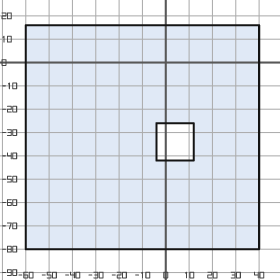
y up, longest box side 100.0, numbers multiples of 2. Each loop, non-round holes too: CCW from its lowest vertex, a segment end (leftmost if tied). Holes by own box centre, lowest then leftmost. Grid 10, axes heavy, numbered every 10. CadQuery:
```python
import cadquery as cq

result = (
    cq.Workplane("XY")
    .moveTo(-60.0, -80.0)
    .lineTo(40.0, -80.0)
    .lineTo(40.0, 16.0)
    .lineTo(-60.0, 16.0)
    .close()
    .moveTo(-4.0, -42.0)
    .lineTo(12.0, -42.0)
    .lineTo(12.0, -26.0)
    .lineTo(-4.0, -26.0)
    .close()
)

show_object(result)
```